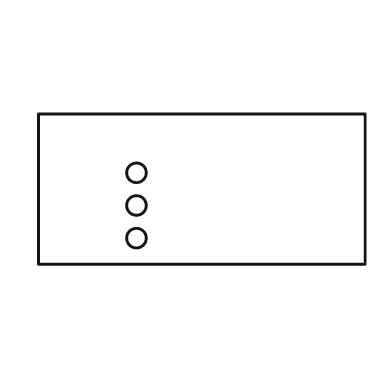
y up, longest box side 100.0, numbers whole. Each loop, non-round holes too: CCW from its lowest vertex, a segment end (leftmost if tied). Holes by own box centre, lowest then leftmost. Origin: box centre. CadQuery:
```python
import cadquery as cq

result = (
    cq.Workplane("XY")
    .moveTo(-50.0, -23.0)
    .lineTo(50.0, -23.0)
    .lineTo(50.0, 23.0)
    .lineTo(-50.0, 23.0)
    .close()
    .moveTo(-20.0, -15.0)
    .circle(3.0)
    .moveTo(-20.0, -5.0)
    .circle(3.0)
    .moveTo(-20.0, 5.0)
    .circle(3.0)
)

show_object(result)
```